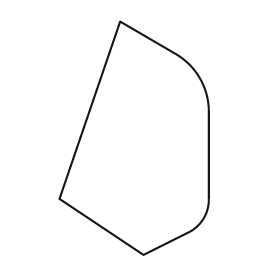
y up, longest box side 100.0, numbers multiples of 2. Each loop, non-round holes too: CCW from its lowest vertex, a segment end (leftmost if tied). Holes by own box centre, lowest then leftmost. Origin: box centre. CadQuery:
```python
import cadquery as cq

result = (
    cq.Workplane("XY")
    .moveTo(4.0, -50.0)
    .lineTo(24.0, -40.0)
    .threePointArc((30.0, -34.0), (32.0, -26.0))
    .lineTo(32.0, 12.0)
    .threePointArc((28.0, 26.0), (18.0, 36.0))
    .lineTo(-6.0, 50.0)
    .lineTo(-32.0, -26.0)
    .close()
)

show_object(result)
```